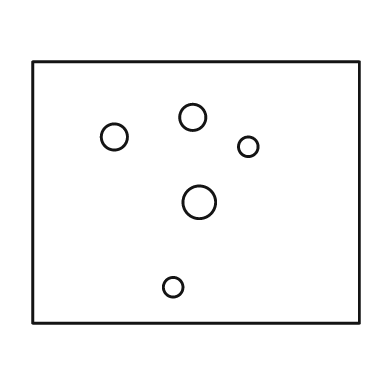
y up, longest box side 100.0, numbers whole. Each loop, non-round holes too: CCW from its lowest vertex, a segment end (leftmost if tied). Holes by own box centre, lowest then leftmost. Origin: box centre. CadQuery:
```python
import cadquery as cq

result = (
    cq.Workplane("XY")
    .moveTo(-50.0, -40.0)
    .lineTo(50.0, -40.0)
    .lineTo(50.0, 40.0)
    .lineTo(-50.0, 40.0)
    .close()
    .moveTo(-7.0, -29.0)
    .circle(3.0)
    .moveTo(1.0, -3.0)
    .circle(5.0)
    .moveTo(16.0, 14.0)
    .circle(3.0)
    .moveTo(-25.0, 17.0)
    .circle(4.0)
    .moveTo(-1.0, 23.0)
    .circle(4.0)
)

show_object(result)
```